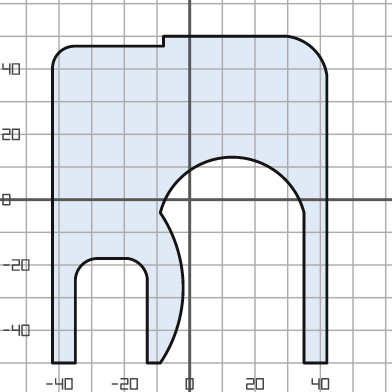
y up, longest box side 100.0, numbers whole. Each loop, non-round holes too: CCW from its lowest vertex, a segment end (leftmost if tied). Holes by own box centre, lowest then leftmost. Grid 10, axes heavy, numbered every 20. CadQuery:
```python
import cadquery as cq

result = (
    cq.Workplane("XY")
    .moveTo(-42.0, -50.0)
    .lineTo(-35.0, -50.0)
    .lineTo(-35.0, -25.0)
    .threePointArc((-33.0, -20.0), (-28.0, -18.0))
    .lineTo(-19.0, -18.0)
    .threePointArc((-15.0, -20.0), (-13.0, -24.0))
    .lineTo(-13.0, -50.0)
    .lineTo(-9.0, -50.0)
    .threePointArc((-2.0, -27.0), (-9.0, -4.0))
    .threePointArc((13.0, 13.0), (35.0, -4.0))
    .lineTo(35.0, -50.0)
    .lineTo(42.0, -50.0)
    .lineTo(42.0, 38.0)
    .threePointArc((38.0, 46.0), (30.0, 50.0))
    .lineTo(-8.0, 50.0)
    .lineTo(-8.0, 47.0)
    .lineTo(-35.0, 47.0)
    .threePointArc((-40.0, 45.0), (-42.0, 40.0))
    .close()
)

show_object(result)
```